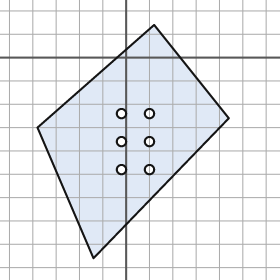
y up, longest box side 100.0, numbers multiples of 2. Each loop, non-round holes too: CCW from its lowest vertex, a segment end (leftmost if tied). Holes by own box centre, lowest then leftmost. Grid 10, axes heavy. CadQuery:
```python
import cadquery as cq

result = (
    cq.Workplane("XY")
    .moveTo(-14.0, -86.0)
    .lineTo(44.0, -26.0)
    .lineTo(12.0, 14.0)
    .lineTo(-38.0, -30.0)
    .close()
    .moveTo(-2.0, -48.0)
    .circle(2.0)
    .moveTo(10.0, -48.0)
    .circle(2.0)
    .moveTo(-2.0, -36.0)
    .circle(2.0)
    .moveTo(10.0, -36.0)
    .circle(2.0)
    .moveTo(-2.0, -24.0)
    .circle(2.0)
    .moveTo(10.0, -24.0)
    .circle(2.0)
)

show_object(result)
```